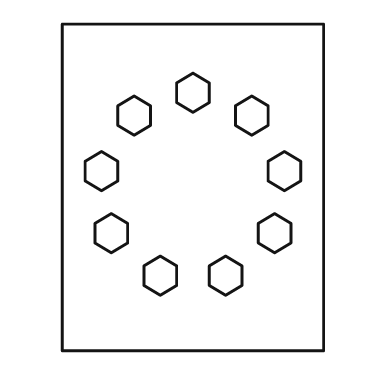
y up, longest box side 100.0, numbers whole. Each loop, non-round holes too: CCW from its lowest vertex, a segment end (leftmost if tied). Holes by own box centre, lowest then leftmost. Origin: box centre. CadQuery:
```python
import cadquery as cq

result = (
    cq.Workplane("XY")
    .moveTo(-40.0, -50.0)
    .lineTo(40.0, -50.0)
    .lineTo(40.0, 50.0)
    .lineTo(-40.0, 50.0)
    .close()
    .moveTo(-10.0, -33.0)
    .lineTo(-5.0, -30.0)
    .lineTo(-5.0, -24.0)
    .lineTo(-10.0, -21.0)
    .lineTo(-15.0, -24.0)
    .lineTo(-15.0, -30.0)
    .close()
    .moveTo(10.0, -33.0)
    .lineTo(15.0, -30.0)
    .lineTo(15.0, -24.0)
    .lineTo(10.0, -21.0)
    .lineTo(5.0, -24.0)
    .lineTo(5.0, -30.0)
    .close()
    .moveTo(-25.0, -20.0)
    .lineTo(-20.0, -17.0)
    .lineTo(-20.0, -11.0)
    .lineTo(-25.0, -8.0)
    .lineTo(-30.0, -11.0)
    .lineTo(-30.0, -17.0)
    .close()
    .moveTo(25.0, -20.0)
    .lineTo(30.0, -17.0)
    .lineTo(30.0, -11.0)
    .lineTo(25.0, -8.0)
    .lineTo(20.0, -11.0)
    .lineTo(20.0, -17.0)
    .close()
    .moveTo(-28.0, -1.0)
    .lineTo(-23.0, 2.0)
    .lineTo(-23.0, 8.0)
    .lineTo(-28.0, 11.0)
    .lineTo(-33.0, 8.0)
    .lineTo(-33.0, 2.0)
    .close()
    .moveTo(28.0, -1.0)
    .lineTo(33.0, 2.0)
    .lineTo(33.0, 8.0)
    .lineTo(28.0, 11.0)
    .lineTo(23.0, 8.0)
    .lineTo(23.0, 2.0)
    .close()
    .moveTo(-18.0, 16.0)
    .lineTo(-13.0, 19.0)
    .lineTo(-13.0, 25.0)
    .lineTo(-18.0, 28.0)
    .lineTo(-23.0, 25.0)
    .lineTo(-23.0, 19.0)
    .close()
    .moveTo(18.0, 16.0)
    .lineTo(23.0, 19.0)
    .lineTo(23.0, 25.0)
    .lineTo(18.0, 28.0)
    .lineTo(13.0, 25.0)
    .lineTo(13.0, 19.0)
    .close()
    .moveTo(0.0, 23.0)
    .lineTo(5.0, 26.0)
    .lineTo(5.0, 32.0)
    .lineTo(0.0, 35.0)
    .lineTo(-5.0, 32.0)
    .lineTo(-5.0, 26.0)
    .close()
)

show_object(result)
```